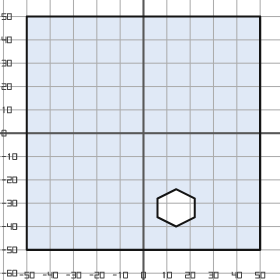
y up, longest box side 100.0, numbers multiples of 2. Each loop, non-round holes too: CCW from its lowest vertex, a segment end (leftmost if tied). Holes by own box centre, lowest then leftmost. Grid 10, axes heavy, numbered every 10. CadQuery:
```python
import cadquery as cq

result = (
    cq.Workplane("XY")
    .moveTo(-50.0, -50.0)
    .lineTo(50.0, -50.0)
    .lineTo(50.0, 50.0)
    .lineTo(-50.0, 50.0)
    .close()
    .moveTo(14.0, -40.0)
    .lineTo(22.0, -36.0)
    .lineTo(22.0, -28.0)
    .lineTo(14.0, -24.0)
    .lineTo(6.0, -28.0)
    .lineTo(6.0, -36.0)
    .close()
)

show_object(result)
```